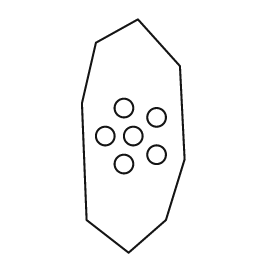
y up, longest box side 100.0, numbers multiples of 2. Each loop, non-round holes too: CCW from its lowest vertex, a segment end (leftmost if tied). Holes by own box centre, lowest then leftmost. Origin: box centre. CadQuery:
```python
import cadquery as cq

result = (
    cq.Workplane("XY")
    .moveTo(-2.0, -50.0)
    .lineTo(14.0, -36.0)
    .lineTo(22.0, -10.0)
    .lineTo(20.0, 30.0)
    .lineTo(2.0, 50.0)
    .lineTo(-16.0, 40.0)
    .lineTo(-22.0, 14.0)
    .lineTo(-20.0, -36.0)
    .close()
    .moveTo(-4.0, -12.0)
    .circle(4.0)
    .moveTo(10.0, -8.0)
    .circle(4.0)
    .moveTo(-12.0, 0.0)
    .circle(4.0)
    .moveTo(0.0, 0.0)
    .circle(4.0)
    .moveTo(10.0, 8.0)
    .circle(4.0)
    .moveTo(-4.0, 12.0)
    .circle(4.0)
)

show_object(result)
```